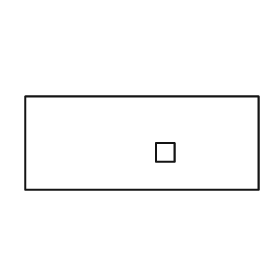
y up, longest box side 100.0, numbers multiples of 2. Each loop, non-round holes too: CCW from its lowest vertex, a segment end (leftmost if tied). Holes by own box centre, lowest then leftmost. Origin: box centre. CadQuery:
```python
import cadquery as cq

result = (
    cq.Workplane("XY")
    .moveTo(-50.0, -20.0)
    .lineTo(50.0, -20.0)
    .lineTo(50.0, 20.0)
    .lineTo(-50.0, 20.0)
    .close()
    .moveTo(6.0, -8.0)
    .lineTo(14.0, -8.0)
    .lineTo(14.0, 0.0)
    .lineTo(6.0, 0.0)
    .close()
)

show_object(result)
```